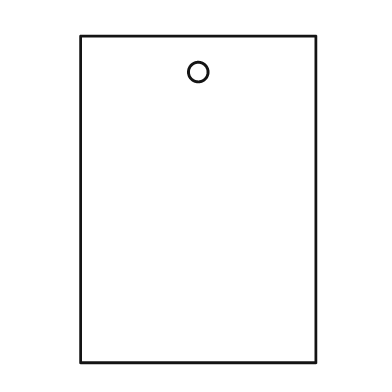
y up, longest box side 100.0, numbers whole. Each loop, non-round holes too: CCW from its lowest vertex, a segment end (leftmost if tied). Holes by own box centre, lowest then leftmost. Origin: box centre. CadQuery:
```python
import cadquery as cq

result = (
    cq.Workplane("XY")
    .moveTo(-36.0, -50.0)
    .lineTo(36.0, -50.0)
    .lineTo(36.0, 50.0)
    .lineTo(-36.0, 50.0)
    .close()
    .moveTo(0.0, 39.0)
    .circle(3.0)
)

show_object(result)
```